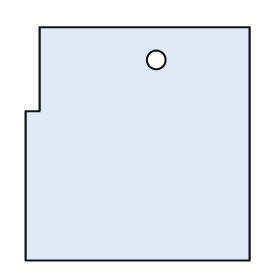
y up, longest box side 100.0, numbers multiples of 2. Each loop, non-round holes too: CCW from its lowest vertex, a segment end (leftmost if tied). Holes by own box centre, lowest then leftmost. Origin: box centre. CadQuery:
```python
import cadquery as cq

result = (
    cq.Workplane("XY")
    .moveTo(-48.0, -50.0)
    .lineTo(48.0, -50.0)
    .lineTo(48.0, 50.0)
    .lineTo(-42.0, 50.0)
    .lineTo(-42.0, 14.0)
    .lineTo(-48.0, 14.0)
    .close()
    .moveTo(8.0, 36.0)
    .circle(4.0)
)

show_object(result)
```